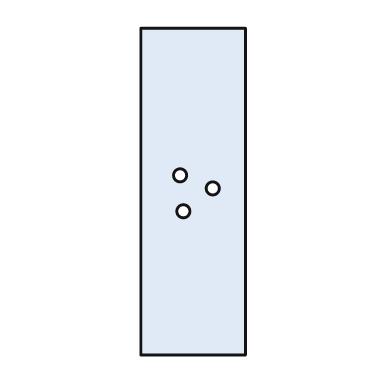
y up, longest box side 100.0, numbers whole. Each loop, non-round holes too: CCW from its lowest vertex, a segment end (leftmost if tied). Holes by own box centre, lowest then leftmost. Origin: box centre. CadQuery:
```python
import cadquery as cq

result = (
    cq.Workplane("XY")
    .moveTo(-16.0, -50.0)
    .lineTo(16.0, -50.0)
    .lineTo(16.0, 50.0)
    .lineTo(-16.0, 50.0)
    .close()
    .moveTo(-3.0, -6.0)
    .circle(2.0)
    .moveTo(6.0, 1.0)
    .circle(2.0)
    .moveTo(-4.0, 5.0)
    .circle(2.0)
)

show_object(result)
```